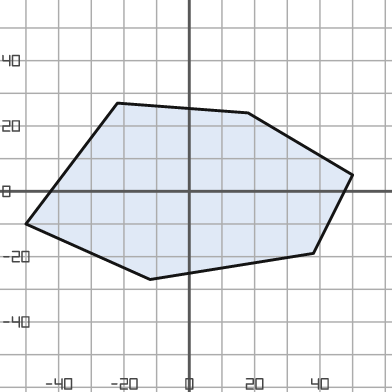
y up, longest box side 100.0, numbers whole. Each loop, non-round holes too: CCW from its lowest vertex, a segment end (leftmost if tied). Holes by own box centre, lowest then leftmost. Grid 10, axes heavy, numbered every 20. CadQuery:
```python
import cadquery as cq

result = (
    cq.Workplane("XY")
    .moveTo(-12.0, -27.0)
    .lineTo(38.0, -19.0)
    .lineTo(50.0, 5.0)
    .lineTo(18.0, 24.0)
    .lineTo(-22.0, 27.0)
    .lineTo(-50.0, -10.0)
    .close()
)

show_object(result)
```